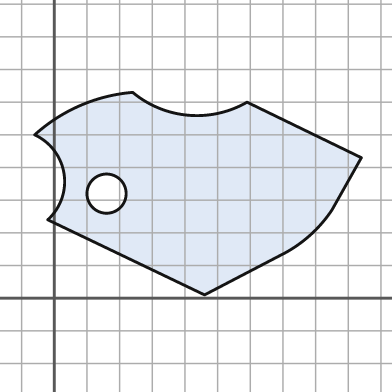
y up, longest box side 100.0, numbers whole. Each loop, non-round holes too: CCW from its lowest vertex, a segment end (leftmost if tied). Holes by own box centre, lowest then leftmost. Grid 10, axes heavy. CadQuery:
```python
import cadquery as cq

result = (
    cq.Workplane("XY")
    .moveTo(46.0, 1.0)
    .lineTo(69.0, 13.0)
    .threePointArc((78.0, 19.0), (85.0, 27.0))
    .lineTo(94.0, 43.0)
    .lineTo(59.0, 60.0)
    .threePointArc((41.0, 56.0), (24.0, 63.0))
    .threePointArc((8.0, 59.0), (-6.0, 50.0))
    .threePointArc((3.0, 38.0), (-2.0, 24.0))
    .close()
    .moveTo(16.0, 32.0)
    .circle(6.0)
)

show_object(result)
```